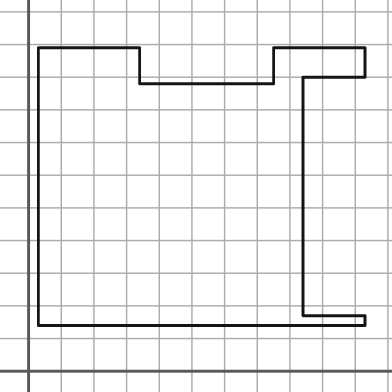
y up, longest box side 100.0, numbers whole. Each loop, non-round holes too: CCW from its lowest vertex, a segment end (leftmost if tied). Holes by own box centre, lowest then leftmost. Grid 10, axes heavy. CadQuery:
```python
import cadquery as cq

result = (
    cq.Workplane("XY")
    .moveTo(3.0, 14.0)
    .lineTo(103.0, 14.0)
    .lineTo(103.0, 17.0)
    .lineTo(84.0, 17.0)
    .lineTo(84.0, 90.0)
    .lineTo(103.0, 90.0)
    .lineTo(103.0, 99.0)
    .lineTo(75.0, 99.0)
    .lineTo(75.0, 88.0)
    .lineTo(34.0, 88.0)
    .lineTo(34.0, 99.0)
    .lineTo(3.0, 99.0)
    .close()
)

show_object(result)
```